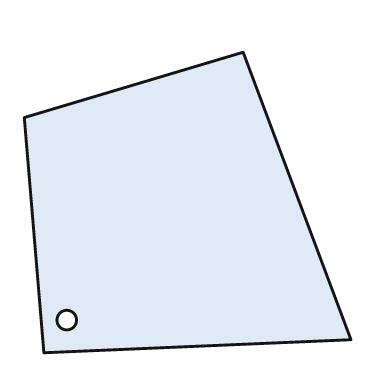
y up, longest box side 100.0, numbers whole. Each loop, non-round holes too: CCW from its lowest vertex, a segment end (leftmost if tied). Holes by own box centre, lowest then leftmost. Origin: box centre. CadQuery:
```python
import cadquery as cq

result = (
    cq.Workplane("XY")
    .moveTo(-44.0, -46.0)
    .lineTo(50.0, -42.0)
    .lineTo(17.0, 46.0)
    .lineTo(-50.0, 26.0)
    .close()
    .moveTo(-37.0, -36.0)
    .circle(3.0)
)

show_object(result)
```